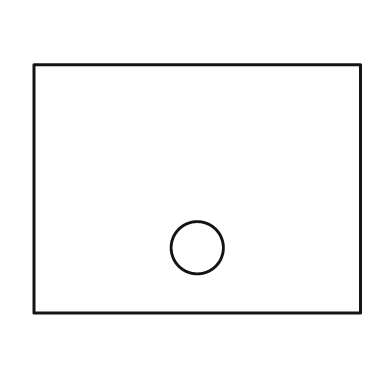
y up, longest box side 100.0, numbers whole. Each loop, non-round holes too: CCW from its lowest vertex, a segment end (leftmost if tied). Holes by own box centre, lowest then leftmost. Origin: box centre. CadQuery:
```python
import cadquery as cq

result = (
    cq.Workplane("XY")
    .moveTo(-50.0, -38.0)
    .lineTo(50.0, -38.0)
    .lineTo(50.0, 38.0)
    .lineTo(-50.0, 38.0)
    .close()
    .moveTo(0.0, -18.0)
    .circle(8.0)
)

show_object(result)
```